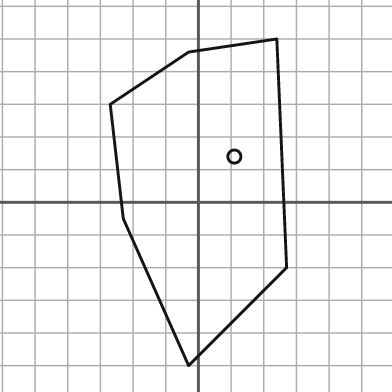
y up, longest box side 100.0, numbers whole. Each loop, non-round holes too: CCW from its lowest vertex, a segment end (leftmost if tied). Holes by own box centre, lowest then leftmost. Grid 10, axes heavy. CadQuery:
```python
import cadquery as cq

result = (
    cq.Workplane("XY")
    .moveTo(-3.0, -50.0)
    .lineTo(27.0, -20.0)
    .lineTo(24.0, 50.0)
    .lineTo(-3.0, 46.0)
    .lineTo(-27.0, 30.0)
    .lineTo(-23.0, -5.0)
    .close()
    .moveTo(11.0, 14.0)
    .circle(2.0)
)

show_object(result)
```